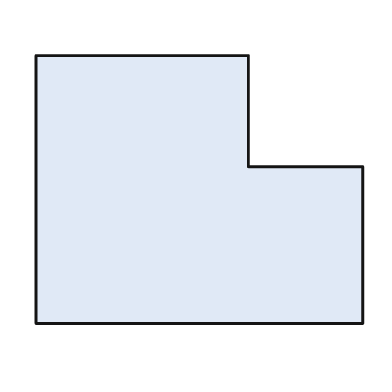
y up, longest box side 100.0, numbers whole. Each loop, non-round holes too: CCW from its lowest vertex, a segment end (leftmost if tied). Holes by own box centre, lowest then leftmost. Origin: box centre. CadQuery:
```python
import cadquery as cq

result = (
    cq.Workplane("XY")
    .moveTo(-50.0, -41.0)
    .lineTo(50.0, -41.0)
    .lineTo(50.0, 7.0)
    .lineTo(15.0, 7.0)
    .lineTo(15.0, 41.0)
    .lineTo(-50.0, 41.0)
    .close()
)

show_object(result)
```